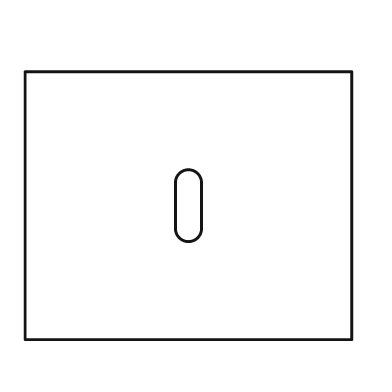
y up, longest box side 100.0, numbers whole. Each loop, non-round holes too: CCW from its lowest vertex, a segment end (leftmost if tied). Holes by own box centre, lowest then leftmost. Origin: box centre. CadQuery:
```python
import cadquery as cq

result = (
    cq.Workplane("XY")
    .moveTo(-50.0, -41.0)
    .lineTo(50.0, -41.0)
    .lineTo(50.0, 41.0)
    .lineTo(-50.0, 41.0)
    .close()
    .moveTo(-4.0, -7.0)
    .threePointArc((0.0, -11.0), (4.0, -7.0))
    .lineTo(4.0, 7.0)
    .threePointArc((0.0, 11.0), (-4.0, 7.0))
    .close()
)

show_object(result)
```